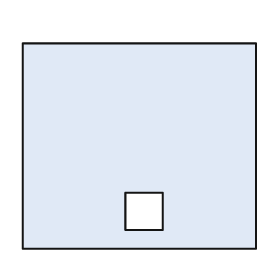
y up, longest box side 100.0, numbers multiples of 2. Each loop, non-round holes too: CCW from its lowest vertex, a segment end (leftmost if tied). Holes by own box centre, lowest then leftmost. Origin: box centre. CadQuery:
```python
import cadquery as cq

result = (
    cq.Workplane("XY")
    .moveTo(-50.0, -44.0)
    .lineTo(50.0, -44.0)
    .lineTo(50.0, 44.0)
    .lineTo(-50.0, 44.0)
    .close()
    .moveTo(-6.0, -36.0)
    .lineTo(10.0, -36.0)
    .lineTo(10.0, -20.0)
    .lineTo(-6.0, -20.0)
    .close()
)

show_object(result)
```